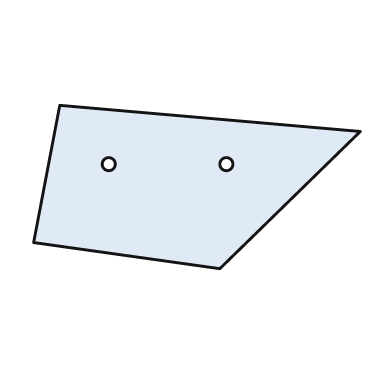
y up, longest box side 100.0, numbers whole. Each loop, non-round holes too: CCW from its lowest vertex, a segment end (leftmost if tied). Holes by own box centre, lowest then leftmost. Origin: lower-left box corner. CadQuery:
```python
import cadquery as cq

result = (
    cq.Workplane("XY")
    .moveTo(57.0, 0.0)
    .lineTo(100.0, 42.0)
    .lineTo(8.0, 50.0)
    .lineTo(0.0, 8.0)
    .close()
    .moveTo(23.0, 32.0)
    .circle(2.0)
    .moveTo(59.0, 32.0)
    .circle(2.0)
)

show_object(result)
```